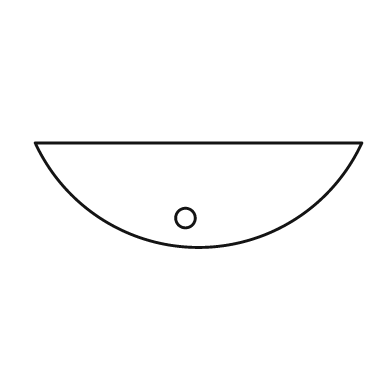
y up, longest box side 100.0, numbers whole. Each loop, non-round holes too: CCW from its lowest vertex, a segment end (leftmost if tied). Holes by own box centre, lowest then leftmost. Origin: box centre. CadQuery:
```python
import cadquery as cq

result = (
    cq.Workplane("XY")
    .moveTo(-50.0, 16.0)
    .threePointArc((0.0, -16.0), (50.0, 16.0))
    .close()
    .moveTo(-4.0, -7.0)
    .circle(3.0)
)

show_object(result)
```